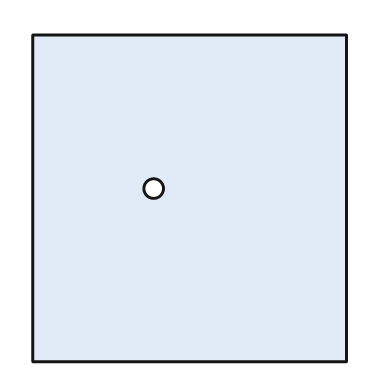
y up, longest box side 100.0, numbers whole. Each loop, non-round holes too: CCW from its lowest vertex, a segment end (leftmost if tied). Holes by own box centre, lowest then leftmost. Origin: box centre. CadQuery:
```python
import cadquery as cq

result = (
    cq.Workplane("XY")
    .moveTo(-48.0, -50.0)
    .lineTo(48.0, -50.0)
    .lineTo(48.0, 50.0)
    .lineTo(-48.0, 50.0)
    .close()
    .moveTo(-11.0, 3.0)
    .circle(3.0)
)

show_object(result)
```